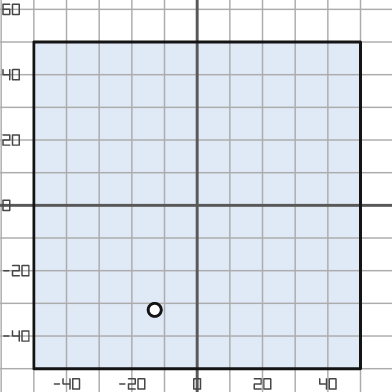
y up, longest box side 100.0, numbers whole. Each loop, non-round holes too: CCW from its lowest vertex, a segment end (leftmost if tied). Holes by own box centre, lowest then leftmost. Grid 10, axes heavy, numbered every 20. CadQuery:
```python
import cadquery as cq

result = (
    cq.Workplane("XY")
    .moveTo(-50.0, -50.0)
    .lineTo(50.0, -50.0)
    .lineTo(50.0, 50.0)
    .lineTo(-50.0, 50.0)
    .close()
    .moveTo(-13.0, -32.0)
    .circle(2.0)
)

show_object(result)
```